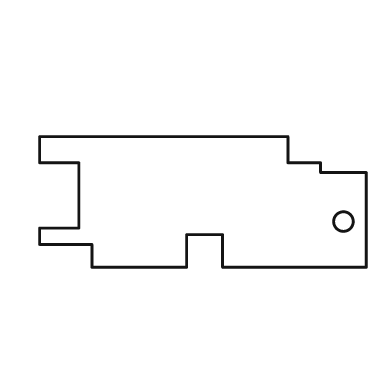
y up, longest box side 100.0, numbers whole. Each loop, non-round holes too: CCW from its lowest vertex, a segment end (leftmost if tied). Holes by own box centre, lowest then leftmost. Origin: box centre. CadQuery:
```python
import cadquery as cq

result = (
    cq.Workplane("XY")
    .moveTo(-34.0, -20.0)
    .lineTo(-5.0, -20.0)
    .lineTo(-5.0, -10.0)
    .lineTo(6.0, -10.0)
    .lineTo(6.0, -20.0)
    .lineTo(50.0, -20.0)
    .lineTo(50.0, 9.0)
    .lineTo(36.0, 9.0)
    .lineTo(36.0, 12.0)
    .lineTo(26.0, 12.0)
    .lineTo(26.0, 20.0)
    .lineTo(-50.0, 20.0)
    .lineTo(-50.0, 12.0)
    .lineTo(-38.0, 12.0)
    .lineTo(-38.0, -8.0)
    .lineTo(-50.0, -8.0)
    .lineTo(-50.0, -13.0)
    .lineTo(-34.0, -13.0)
    .close()
    .moveTo(43.0, -6.0)
    .circle(3.0)
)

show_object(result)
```